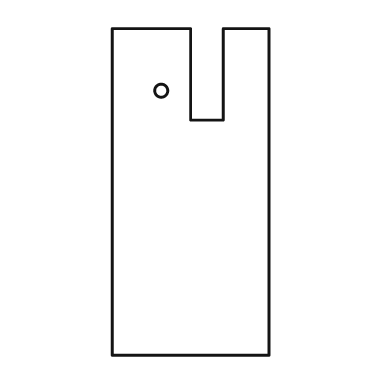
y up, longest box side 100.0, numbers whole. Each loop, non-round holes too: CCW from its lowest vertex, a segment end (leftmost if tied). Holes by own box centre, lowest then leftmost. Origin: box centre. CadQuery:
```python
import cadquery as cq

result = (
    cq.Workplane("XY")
    .moveTo(-24.0, -50.0)
    .lineTo(24.0, -50.0)
    .lineTo(24.0, 50.0)
    .lineTo(10.0, 50.0)
    .lineTo(10.0, 22.0)
    .lineTo(0.0, 22.0)
    .lineTo(0.0, 50.0)
    .lineTo(-24.0, 50.0)
    .close()
    .moveTo(-9.0, 31.0)
    .circle(2.0)
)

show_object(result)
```